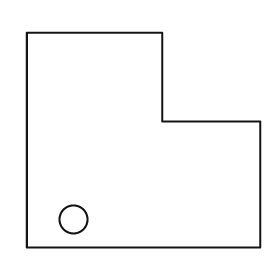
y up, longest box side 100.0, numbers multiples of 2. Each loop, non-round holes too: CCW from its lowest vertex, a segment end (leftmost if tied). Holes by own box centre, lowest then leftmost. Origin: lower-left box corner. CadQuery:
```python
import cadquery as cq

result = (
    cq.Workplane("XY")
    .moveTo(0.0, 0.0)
    .lineTo(100.0, 0.0)
    .lineTo(100.0, 54.0)
    .lineTo(58.0, 54.0)
    .lineTo(58.0, 92.0)
    .lineTo(0.0, 92.0)
    .close()
    .moveTo(20.0, 12.0)
    .circle(6.0)
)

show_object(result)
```